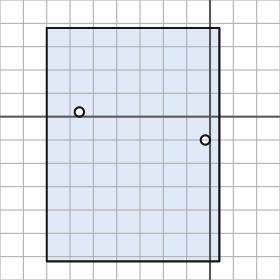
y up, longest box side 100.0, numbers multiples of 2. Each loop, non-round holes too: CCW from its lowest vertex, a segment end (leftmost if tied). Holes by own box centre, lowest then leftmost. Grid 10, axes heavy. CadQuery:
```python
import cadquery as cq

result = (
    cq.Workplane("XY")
    .moveTo(-70.0, -62.0)
    .lineTo(4.0, -62.0)
    .lineTo(4.0, 38.0)
    .lineTo(-70.0, 38.0)
    .close()
    .moveTo(-2.0, -10.0)
    .circle(2.0)
    .moveTo(-56.0, 2.0)
    .circle(2.0)
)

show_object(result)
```